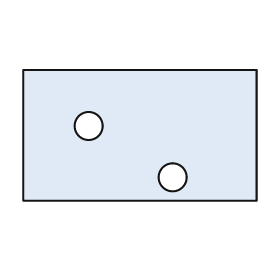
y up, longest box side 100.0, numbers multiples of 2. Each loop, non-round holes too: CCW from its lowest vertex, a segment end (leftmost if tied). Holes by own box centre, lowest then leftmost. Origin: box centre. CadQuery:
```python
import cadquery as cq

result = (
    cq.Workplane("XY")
    .moveTo(-50.0, -28.0)
    .lineTo(50.0, -28.0)
    .lineTo(50.0, 28.0)
    .lineTo(-50.0, 28.0)
    .close()
    .moveTo(14.0, -18.0)
    .circle(6.0)
    .moveTo(-22.0, 4.0)
    .circle(6.0)
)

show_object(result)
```